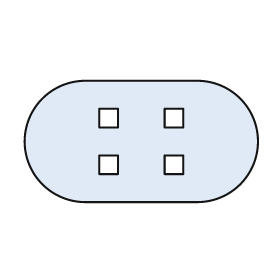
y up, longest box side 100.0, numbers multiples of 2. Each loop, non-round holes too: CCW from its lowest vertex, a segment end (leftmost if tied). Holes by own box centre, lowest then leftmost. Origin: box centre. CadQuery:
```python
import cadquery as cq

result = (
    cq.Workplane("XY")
    .moveTo(-24.0, -26.0)
    .lineTo(24.0, -26.0)
    .threePointArc((50.0, 0.0), (24.0, 26.0))
    .lineTo(-24.0, 26.0)
    .threePointArc((-50.0, 0.0), (-24.0, -26.0))
    .close()
    .moveTo(-18.0, -14.0)
    .lineTo(-10.0, -14.0)
    .lineTo(-10.0, -6.0)
    .lineTo(-18.0, -6.0)
    .close()
    .moveTo(10.0, -14.0)
    .lineTo(18.0, -14.0)
    .lineTo(18.0, -6.0)
    .lineTo(10.0, -6.0)
    .close()
    .moveTo(-18.0, 6.0)
    .lineTo(-10.0, 6.0)
    .lineTo(-10.0, 14.0)
    .lineTo(-18.0, 14.0)
    .close()
    .moveTo(10.0, 6.0)
    .lineTo(18.0, 6.0)
    .lineTo(18.0, 14.0)
    .lineTo(10.0, 14.0)
    .close()
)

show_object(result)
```